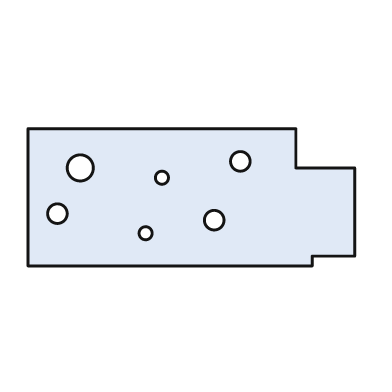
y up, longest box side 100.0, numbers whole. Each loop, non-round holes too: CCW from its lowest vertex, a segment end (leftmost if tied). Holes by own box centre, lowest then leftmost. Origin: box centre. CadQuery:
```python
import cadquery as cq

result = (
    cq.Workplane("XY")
    .moveTo(-50.0, -21.0)
    .lineTo(37.0, -21.0)
    .lineTo(37.0, -18.0)
    .lineTo(50.0, -18.0)
    .lineTo(50.0, 9.0)
    .lineTo(32.0, 9.0)
    .lineTo(32.0, 21.0)
    .lineTo(-50.0, 21.0)
    .close()
    .moveTo(-14.0, -11.0)
    .circle(2.0)
    .moveTo(7.0, -7.0)
    .circle(3.0)
    .moveTo(-41.0, -5.0)
    .circle(3.0)
    .moveTo(-9.0, 6.0)
    .circle(2.0)
    .moveTo(-34.0, 9.0)
    .circle(4.0)
    .moveTo(15.0, 11.0)
    .circle(3.0)
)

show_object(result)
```